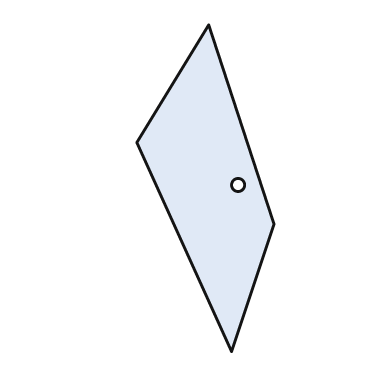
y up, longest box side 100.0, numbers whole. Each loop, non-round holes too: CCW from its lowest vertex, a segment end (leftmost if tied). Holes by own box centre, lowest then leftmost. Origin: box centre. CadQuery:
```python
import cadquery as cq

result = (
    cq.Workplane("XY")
    .moveTo(8.0, -50.0)
    .lineTo(21.0, -11.0)
    .lineTo(1.0, 50.0)
    .lineTo(-21.0, 14.0)
    .close()
    .moveTo(10.0, 1.0)
    .circle(2.0)
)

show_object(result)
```